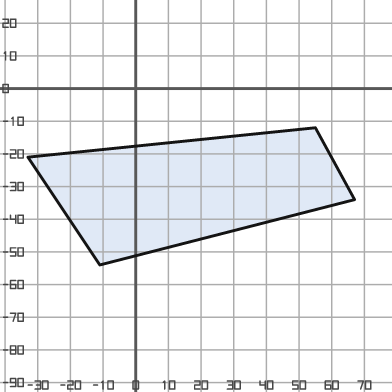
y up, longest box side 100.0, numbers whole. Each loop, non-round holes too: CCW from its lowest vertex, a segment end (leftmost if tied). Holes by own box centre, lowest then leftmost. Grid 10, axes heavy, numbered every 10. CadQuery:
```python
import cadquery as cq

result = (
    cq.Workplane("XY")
    .moveTo(-11.0, -54.0)
    .lineTo(67.0, -34.0)
    .lineTo(55.0, -12.0)
    .lineTo(-33.0, -21.0)
    .close()
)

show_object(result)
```